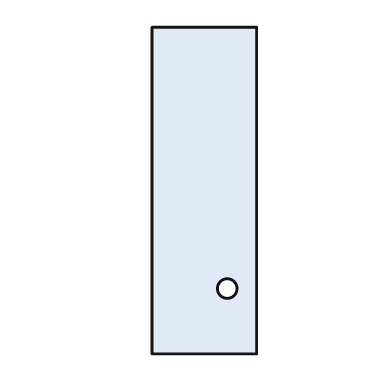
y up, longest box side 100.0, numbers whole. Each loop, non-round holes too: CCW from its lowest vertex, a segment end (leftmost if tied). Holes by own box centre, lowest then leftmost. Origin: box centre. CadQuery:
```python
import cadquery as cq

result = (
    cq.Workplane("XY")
    .moveTo(-16.0, -50.0)
    .lineTo(16.0, -50.0)
    .lineTo(16.0, 50.0)
    .lineTo(-16.0, 50.0)
    .close()
    .moveTo(7.0, -30.0)
    .circle(3.0)
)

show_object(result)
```